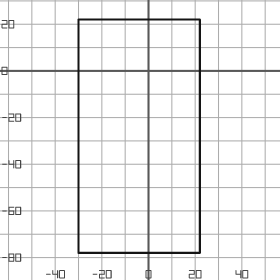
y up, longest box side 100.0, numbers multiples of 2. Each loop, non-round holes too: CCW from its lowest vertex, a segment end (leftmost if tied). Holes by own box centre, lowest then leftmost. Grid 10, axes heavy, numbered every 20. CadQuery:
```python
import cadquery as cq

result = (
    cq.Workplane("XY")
    .moveTo(-30.0, -78.0)
    .lineTo(22.0, -78.0)
    .lineTo(22.0, 22.0)
    .lineTo(-30.0, 22.0)
    .close()
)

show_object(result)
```